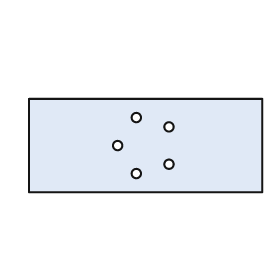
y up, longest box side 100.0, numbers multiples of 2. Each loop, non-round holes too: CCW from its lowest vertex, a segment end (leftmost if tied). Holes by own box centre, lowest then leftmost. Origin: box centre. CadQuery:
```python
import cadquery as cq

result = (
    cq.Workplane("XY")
    .moveTo(-50.0, -20.0)
    .lineTo(50.0, -20.0)
    .lineTo(50.0, 20.0)
    .lineTo(-50.0, 20.0)
    .close()
    .moveTo(-4.0, -12.0)
    .circle(2.0)
    .moveTo(10.0, -8.0)
    .circle(2.0)
    .moveTo(-12.0, 0.0)
    .circle(2.0)
    .moveTo(10.0, 8.0)
    .circle(2.0)
    .moveTo(-4.0, 12.0)
    .circle(2.0)
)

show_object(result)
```